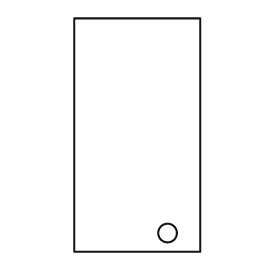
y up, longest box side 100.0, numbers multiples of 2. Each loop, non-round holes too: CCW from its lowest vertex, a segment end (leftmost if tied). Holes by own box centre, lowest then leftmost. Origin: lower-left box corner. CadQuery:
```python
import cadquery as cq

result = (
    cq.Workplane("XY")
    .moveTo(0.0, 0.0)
    .lineTo(54.0, 0.0)
    .lineTo(54.0, 100.0)
    .lineTo(0.0, 100.0)
    .close()
    .moveTo(40.0, 8.0)
    .circle(4.0)
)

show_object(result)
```